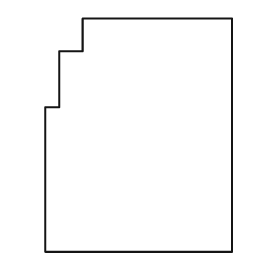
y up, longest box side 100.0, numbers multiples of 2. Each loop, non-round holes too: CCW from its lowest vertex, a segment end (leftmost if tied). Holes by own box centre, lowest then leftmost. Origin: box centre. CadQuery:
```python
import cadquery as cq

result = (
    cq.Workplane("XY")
    .moveTo(-40.0, -50.0)
    .lineTo(40.0, -50.0)
    .lineTo(40.0, 50.0)
    .lineTo(-24.0, 50.0)
    .lineTo(-24.0, 36.0)
    .lineTo(-34.0, 36.0)
    .lineTo(-34.0, 12.0)
    .lineTo(-40.0, 12.0)
    .close()
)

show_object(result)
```